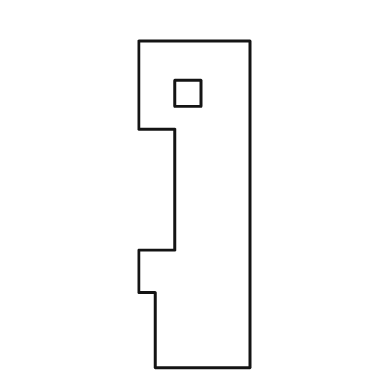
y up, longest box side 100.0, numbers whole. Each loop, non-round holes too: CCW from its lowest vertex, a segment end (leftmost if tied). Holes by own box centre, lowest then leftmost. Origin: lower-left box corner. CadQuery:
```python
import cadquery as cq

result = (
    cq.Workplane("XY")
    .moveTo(5.0, 0.0)
    .lineTo(34.0, 0.0)
    .lineTo(34.0, 100.0)
    .lineTo(0.0, 100.0)
    .lineTo(0.0, 73.0)
    .lineTo(11.0, 73.0)
    .lineTo(11.0, 36.0)
    .lineTo(0.0, 36.0)
    .lineTo(0.0, 23.0)
    .lineTo(5.0, 23.0)
    .close()
    .moveTo(11.0, 80.0)
    .lineTo(19.0, 80.0)
    .lineTo(19.0, 88.0)
    .lineTo(11.0, 88.0)
    .close()
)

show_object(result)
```